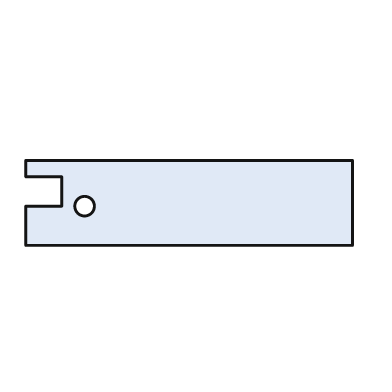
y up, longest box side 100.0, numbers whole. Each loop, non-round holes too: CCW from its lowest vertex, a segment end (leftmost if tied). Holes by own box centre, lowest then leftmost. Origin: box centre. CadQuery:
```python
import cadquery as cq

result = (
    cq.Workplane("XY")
    .moveTo(-50.0, -13.0)
    .lineTo(50.0, -13.0)
    .lineTo(50.0, 13.0)
    .lineTo(-50.0, 13.0)
    .lineTo(-50.0, 8.0)
    .lineTo(-39.0, 8.0)
    .lineTo(-39.0, -1.0)
    .lineTo(-50.0, -1.0)
    .close()
    .moveTo(-32.0, -1.0)
    .circle(3.0)
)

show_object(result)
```